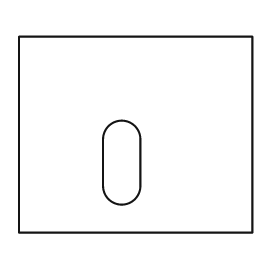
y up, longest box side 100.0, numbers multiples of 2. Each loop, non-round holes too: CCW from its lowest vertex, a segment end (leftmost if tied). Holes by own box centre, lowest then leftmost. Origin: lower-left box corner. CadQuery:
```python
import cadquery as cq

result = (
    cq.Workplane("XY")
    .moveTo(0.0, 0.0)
    .lineTo(100.0, 0.0)
    .lineTo(100.0, 84.0)
    .lineTo(0.0, 84.0)
    .close()
    .moveTo(36.0, 20.0)
    .threePointArc((44.0, 12.0), (52.0, 20.0))
    .lineTo(52.0, 40.0)
    .threePointArc((44.0, 48.0), (36.0, 40.0))
    .close()
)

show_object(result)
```